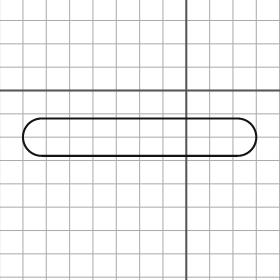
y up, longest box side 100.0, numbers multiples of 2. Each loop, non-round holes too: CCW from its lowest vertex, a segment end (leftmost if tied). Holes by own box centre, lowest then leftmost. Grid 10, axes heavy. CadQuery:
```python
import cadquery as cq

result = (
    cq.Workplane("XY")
    .moveTo(-62.0, -28.0)
    .lineTo(22.0, -28.0)
    .threePointArc((30.0, -20.0), (22.0, -12.0))
    .lineTo(-62.0, -12.0)
    .threePointArc((-70.0, -20.0), (-62.0, -28.0))
    .close()
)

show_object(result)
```